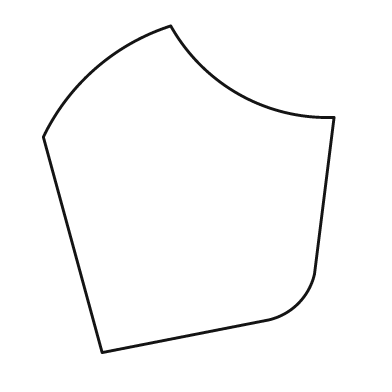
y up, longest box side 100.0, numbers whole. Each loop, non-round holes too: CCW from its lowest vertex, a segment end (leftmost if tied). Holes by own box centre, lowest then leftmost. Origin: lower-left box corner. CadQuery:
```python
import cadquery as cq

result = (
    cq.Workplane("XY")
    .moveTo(18.0, 0.0)
    .lineTo(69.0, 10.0)
    .threePointArc((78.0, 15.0), (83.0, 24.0))
    .lineTo(89.0, 72.0)
    .threePointArc((60.0, 79.0), (39.0, 100.0))
    .threePointArc((16.0, 87.0), (0.0, 66.0))
    .close()
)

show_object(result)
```